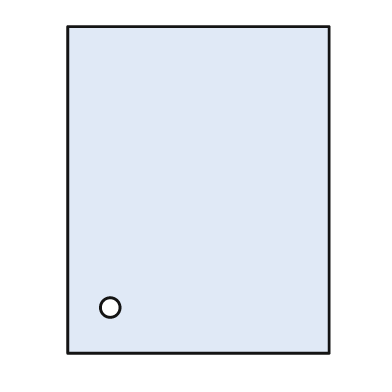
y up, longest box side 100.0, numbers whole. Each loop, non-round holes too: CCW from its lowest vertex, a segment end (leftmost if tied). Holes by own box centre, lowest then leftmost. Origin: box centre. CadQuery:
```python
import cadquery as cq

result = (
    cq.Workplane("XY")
    .moveTo(-40.0, -50.0)
    .lineTo(40.0, -50.0)
    .lineTo(40.0, 50.0)
    .lineTo(-40.0, 50.0)
    .close()
    .moveTo(-27.0, -36.0)
    .circle(3.0)
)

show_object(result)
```